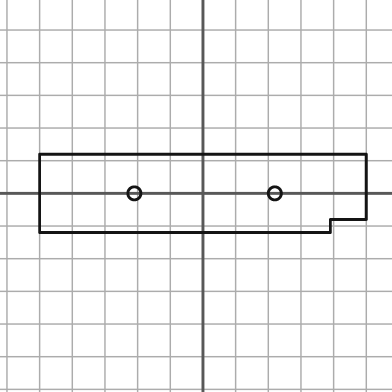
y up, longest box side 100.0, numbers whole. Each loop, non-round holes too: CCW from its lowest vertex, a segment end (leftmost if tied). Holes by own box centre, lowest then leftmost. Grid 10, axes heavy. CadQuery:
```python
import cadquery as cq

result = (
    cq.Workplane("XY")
    .moveTo(-50.0, -12.0)
    .lineTo(39.0, -12.0)
    .lineTo(39.0, -8.0)
    .lineTo(50.0, -8.0)
    .lineTo(50.0, 12.0)
    .lineTo(-50.0, 12.0)
    .close()
    .moveTo(-21.0, 0.0)
    .circle(2.0)
    .moveTo(22.0, 0.0)
    .circle(2.0)
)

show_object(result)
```